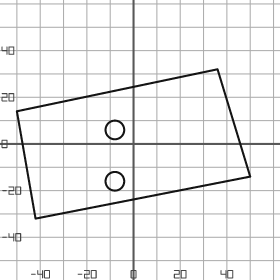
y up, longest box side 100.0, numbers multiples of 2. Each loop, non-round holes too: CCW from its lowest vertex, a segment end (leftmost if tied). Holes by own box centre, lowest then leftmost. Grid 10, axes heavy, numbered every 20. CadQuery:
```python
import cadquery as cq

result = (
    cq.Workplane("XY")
    .moveTo(-42.0, -32.0)
    .lineTo(50.0, -14.0)
    .lineTo(36.0, 32.0)
    .lineTo(-50.0, 14.0)
    .close()
    .moveTo(-8.0, -16.0)
    .circle(4.0)
    .moveTo(-8.0, 6.0)
    .circle(4.0)
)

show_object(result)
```